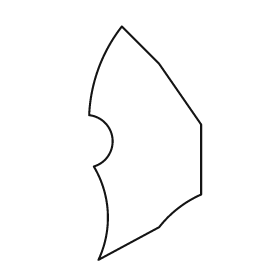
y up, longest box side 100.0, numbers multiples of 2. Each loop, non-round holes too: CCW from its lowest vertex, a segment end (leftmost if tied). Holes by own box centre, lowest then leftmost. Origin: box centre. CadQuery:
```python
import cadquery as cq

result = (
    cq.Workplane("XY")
    .moveTo(-20.0, -50.0)
    .lineTo(6.0, -36.0)
    .threePointArc((14.0, -28.0), (24.0, -22.0))
    .lineTo(24.0, 8.0)
    .lineTo(6.0, 34.0)
    .lineTo(-10.0, 50.0)
    .threePointArc((-20.0, 32.0), (-24.0, 12.0))
    .threePointArc((-14.0, 2.0), (-22.0, -10.0))
    .threePointArc((-16.0, -30.0), (-20.0, -50.0))
    .close()
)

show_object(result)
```